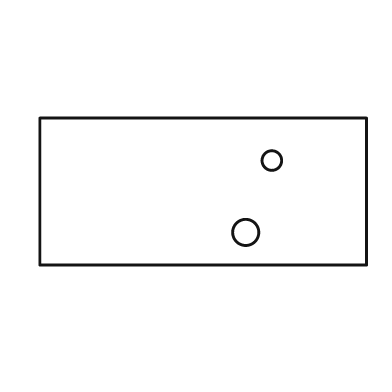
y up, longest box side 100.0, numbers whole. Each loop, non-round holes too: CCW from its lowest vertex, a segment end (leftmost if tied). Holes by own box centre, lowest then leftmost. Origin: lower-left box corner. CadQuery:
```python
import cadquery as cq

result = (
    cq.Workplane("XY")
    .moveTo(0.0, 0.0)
    .lineTo(100.0, 0.0)
    .lineTo(100.0, 45.0)
    .lineTo(0.0, 45.0)
    .close()
    .moveTo(63.0, 10.0)
    .circle(4.0)
    .moveTo(71.0, 32.0)
    .circle(3.0)
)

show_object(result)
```